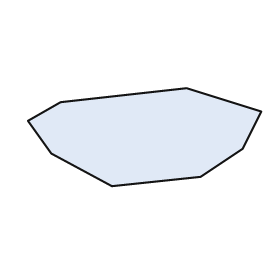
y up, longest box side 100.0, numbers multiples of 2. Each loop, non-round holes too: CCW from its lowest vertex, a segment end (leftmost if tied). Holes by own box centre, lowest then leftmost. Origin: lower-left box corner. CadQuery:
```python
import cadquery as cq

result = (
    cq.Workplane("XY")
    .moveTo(36.0, 0.0)
    .lineTo(74.0, 4.0)
    .lineTo(92.0, 16.0)
    .lineTo(100.0, 32.0)
    .lineTo(68.0, 42.0)
    .lineTo(14.0, 36.0)
    .lineTo(0.0, 28.0)
    .lineTo(10.0, 14.0)
    .close()
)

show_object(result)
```